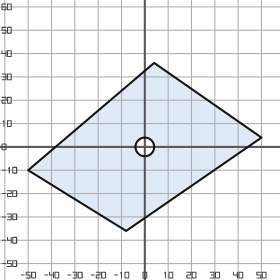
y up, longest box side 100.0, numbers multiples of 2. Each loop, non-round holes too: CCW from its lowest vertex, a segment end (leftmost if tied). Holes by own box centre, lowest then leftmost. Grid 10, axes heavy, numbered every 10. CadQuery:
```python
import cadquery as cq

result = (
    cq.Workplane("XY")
    .moveTo(-8.0, -36.0)
    .lineTo(50.0, 4.0)
    .lineTo(4.0, 36.0)
    .lineTo(-50.0, -10.0)
    .close()
    .moveTo(0.0, 0.0)
    .circle(4.0)
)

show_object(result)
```